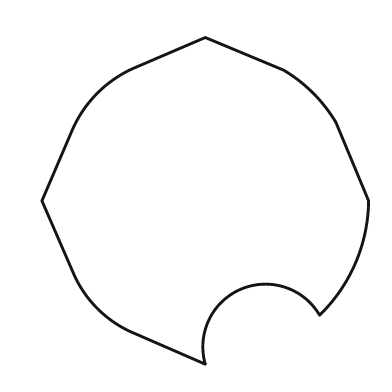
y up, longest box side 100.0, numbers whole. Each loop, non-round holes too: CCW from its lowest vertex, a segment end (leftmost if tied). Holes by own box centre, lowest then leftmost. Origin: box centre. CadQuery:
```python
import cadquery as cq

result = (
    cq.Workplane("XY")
    .moveTo(0.0, -50.0)
    .threePointArc((11.0, -27.0), (35.0, -35.0))
    .threePointArc((46.0, -19.0), (50.0, 0.0))
    .lineTo(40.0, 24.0)
    .threePointArc((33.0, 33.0), (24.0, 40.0))
    .lineTo(0.0, 50.0)
    .lineTo(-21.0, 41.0)
    .threePointArc((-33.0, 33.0), (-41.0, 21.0))
    .lineTo(-50.0, 0.0)
    .lineTo(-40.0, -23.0)
    .threePointArc((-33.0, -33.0), (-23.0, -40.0))
    .close()
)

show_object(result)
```